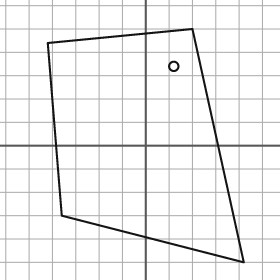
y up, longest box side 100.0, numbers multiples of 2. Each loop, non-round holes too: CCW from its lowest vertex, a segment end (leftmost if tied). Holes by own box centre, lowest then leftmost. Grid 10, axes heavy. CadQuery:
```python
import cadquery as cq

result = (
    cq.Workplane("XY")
    .moveTo(42.0, -50.0)
    .lineTo(20.0, 50.0)
    .lineTo(-42.0, 44.0)
    .lineTo(-36.0, -30.0)
    .close()
    .moveTo(12.0, 34.0)
    .circle(2.0)
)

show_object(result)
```